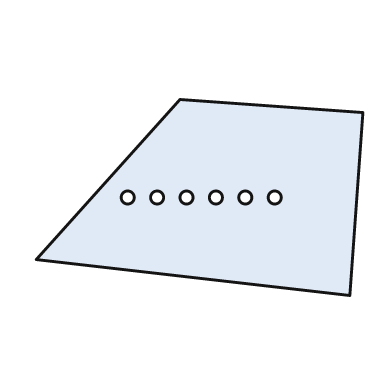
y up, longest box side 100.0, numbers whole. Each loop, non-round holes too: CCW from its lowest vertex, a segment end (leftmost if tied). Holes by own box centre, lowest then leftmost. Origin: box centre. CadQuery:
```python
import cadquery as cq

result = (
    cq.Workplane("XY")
    .moveTo(46.0, -30.0)
    .lineTo(50.0, 26.0)
    .lineTo(-6.0, 30.0)
    .lineTo(-50.0, -19.0)
    .close()
    .moveTo(-22.0, 0.0)
    .circle(2.0)
    .moveTo(-13.0, 0.0)
    .circle(2.0)
    .moveTo(-4.0, 0.0)
    .circle(2.0)
    .moveTo(5.0, 0.0)
    .circle(2.0)
    .moveTo(14.0, 0.0)
    .circle(2.0)
    .moveTo(23.0, 0.0)
    .circle(2.0)
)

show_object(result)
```